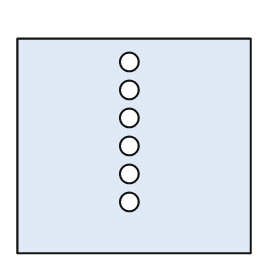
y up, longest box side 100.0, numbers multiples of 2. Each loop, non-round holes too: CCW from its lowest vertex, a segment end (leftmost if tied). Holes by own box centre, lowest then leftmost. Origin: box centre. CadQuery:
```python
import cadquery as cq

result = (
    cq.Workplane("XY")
    .moveTo(-50.0, -46.0)
    .lineTo(50.0, -46.0)
    .lineTo(50.0, 46.0)
    .lineTo(-50.0, 46.0)
    .close()
    .moveTo(-2.0, -24.0)
    .circle(4.0)
    .moveTo(-2.0, -12.0)
    .circle(4.0)
    .moveTo(-2.0, 0.0)
    .circle(4.0)
    .moveTo(-2.0, 12.0)
    .circle(4.0)
    .moveTo(-2.0, 24.0)
    .circle(4.0)
    .moveTo(-2.0, 36.0)
    .circle(4.0)
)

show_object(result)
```